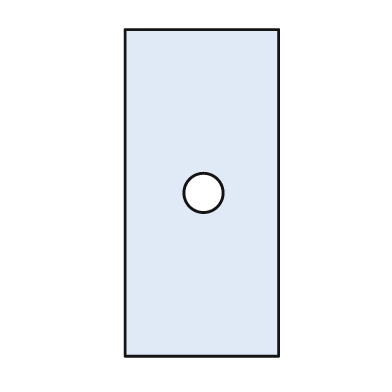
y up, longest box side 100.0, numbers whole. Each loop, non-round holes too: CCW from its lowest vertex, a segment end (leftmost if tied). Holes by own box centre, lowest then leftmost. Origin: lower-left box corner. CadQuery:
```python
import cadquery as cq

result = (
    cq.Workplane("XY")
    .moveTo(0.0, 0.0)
    .lineTo(47.0, 0.0)
    .lineTo(47.0, 100.0)
    .lineTo(0.0, 100.0)
    .close()
    .moveTo(24.0, 50.0)
    .circle(6.0)
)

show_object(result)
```